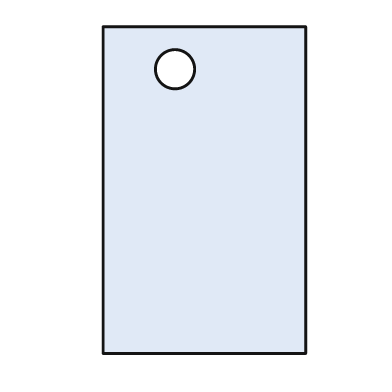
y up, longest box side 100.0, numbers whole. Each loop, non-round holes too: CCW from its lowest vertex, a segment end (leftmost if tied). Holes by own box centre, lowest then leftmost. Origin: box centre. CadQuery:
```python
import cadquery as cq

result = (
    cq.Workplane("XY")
    .moveTo(-31.0, -50.0)
    .lineTo(31.0, -50.0)
    .lineTo(31.0, 50.0)
    .lineTo(-31.0, 50.0)
    .close()
    .moveTo(-9.0, 37.0)
    .circle(6.0)
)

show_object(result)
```